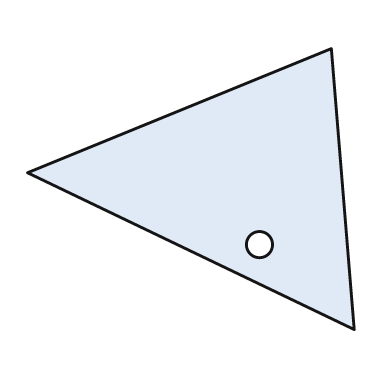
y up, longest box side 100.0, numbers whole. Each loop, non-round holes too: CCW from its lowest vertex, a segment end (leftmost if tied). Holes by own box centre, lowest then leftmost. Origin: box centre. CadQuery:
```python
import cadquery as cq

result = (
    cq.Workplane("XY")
    .moveTo(50.0, -43.0)
    .lineTo(43.0, 43.0)
    .lineTo(-50.0, 5.0)
    .close()
    .moveTo(21.0, -17.0)
    .circle(4.0)
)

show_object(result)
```